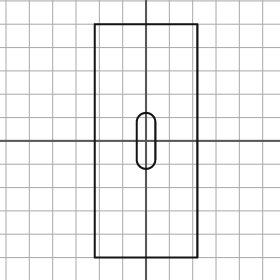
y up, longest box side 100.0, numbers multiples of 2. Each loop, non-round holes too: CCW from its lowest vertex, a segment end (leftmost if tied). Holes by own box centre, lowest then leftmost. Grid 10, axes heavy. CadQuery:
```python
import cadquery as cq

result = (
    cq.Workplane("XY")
    .moveTo(-22.0, -50.0)
    .lineTo(22.0, -50.0)
    .lineTo(22.0, 50.0)
    .lineTo(-22.0, 50.0)
    .close()
    .moveTo(-4.0, -8.0)
    .threePointArc((0.0, -12.0), (4.0, -8.0))
    .lineTo(4.0, 8.0)
    .threePointArc((0.0, 12.0), (-4.0, 8.0))
    .close()
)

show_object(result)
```